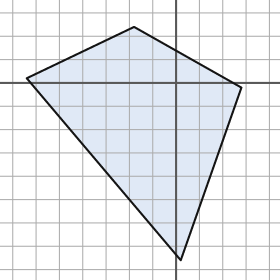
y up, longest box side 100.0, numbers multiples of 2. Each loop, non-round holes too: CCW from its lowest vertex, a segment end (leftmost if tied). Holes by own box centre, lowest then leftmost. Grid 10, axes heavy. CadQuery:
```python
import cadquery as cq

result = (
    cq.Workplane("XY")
    .moveTo(2.0, -76.0)
    .lineTo(28.0, -2.0)
    .lineTo(-18.0, 24.0)
    .lineTo(-64.0, 2.0)
    .close()
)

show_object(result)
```